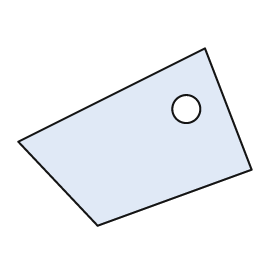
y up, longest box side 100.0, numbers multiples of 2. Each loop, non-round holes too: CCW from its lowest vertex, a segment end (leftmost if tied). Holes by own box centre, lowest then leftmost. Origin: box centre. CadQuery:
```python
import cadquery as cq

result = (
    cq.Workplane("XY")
    .moveTo(-16.0, -38.0)
    .lineTo(50.0, -14.0)
    .lineTo(30.0, 38.0)
    .lineTo(-50.0, -2.0)
    .close()
    .moveTo(22.0, 12.0)
    .circle(6.0)
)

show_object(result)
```